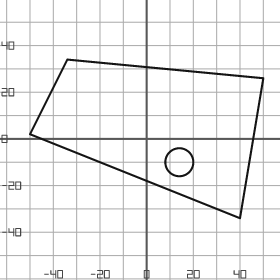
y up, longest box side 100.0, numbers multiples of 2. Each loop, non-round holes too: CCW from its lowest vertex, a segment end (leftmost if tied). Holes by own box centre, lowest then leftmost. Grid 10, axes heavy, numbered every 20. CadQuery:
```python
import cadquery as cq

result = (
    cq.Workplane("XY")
    .moveTo(40.0, -34.0)
    .lineTo(50.0, 26.0)
    .lineTo(-34.0, 34.0)
    .lineTo(-50.0, 2.0)
    .close()
    .moveTo(14.0, -10.0)
    .circle(6.0)
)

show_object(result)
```